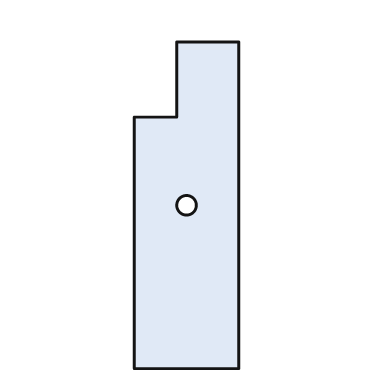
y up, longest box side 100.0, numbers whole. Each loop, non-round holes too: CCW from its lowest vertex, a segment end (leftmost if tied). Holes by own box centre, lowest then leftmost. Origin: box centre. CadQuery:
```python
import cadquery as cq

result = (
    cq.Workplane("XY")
    .moveTo(-16.0, -50.0)
    .lineTo(16.0, -50.0)
    .lineTo(16.0, 50.0)
    .lineTo(-3.0, 50.0)
    .lineTo(-3.0, 27.0)
    .lineTo(-16.0, 27.0)
    .close()
    .moveTo(0.0, 0.0)
    .circle(3.0)
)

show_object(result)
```